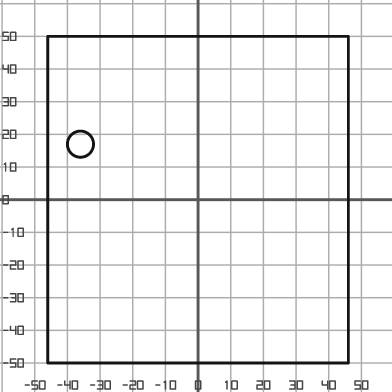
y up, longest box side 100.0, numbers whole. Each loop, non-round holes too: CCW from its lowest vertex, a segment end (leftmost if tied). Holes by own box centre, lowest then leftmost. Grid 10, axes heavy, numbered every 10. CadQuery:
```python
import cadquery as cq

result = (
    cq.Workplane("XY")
    .moveTo(-46.0, -50.0)
    .lineTo(46.0, -50.0)
    .lineTo(46.0, 50.0)
    .lineTo(-46.0, 50.0)
    .close()
    .moveTo(-36.0, 17.0)
    .circle(4.0)
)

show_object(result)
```